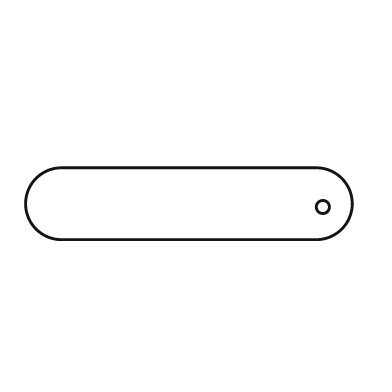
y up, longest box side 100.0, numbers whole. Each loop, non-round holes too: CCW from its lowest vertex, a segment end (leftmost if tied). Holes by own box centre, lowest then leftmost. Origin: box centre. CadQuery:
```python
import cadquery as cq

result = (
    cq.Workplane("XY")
    .moveTo(-39.0, -11.0)
    .lineTo(39.0, -11.0)
    .threePointArc((50.0, 0.0), (39.0, 11.0))
    .lineTo(-39.0, 11.0)
    .threePointArc((-50.0, 0.0), (-39.0, -11.0))
    .close()
    .moveTo(41.0, -1.0)
    .circle(2.0)
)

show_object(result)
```